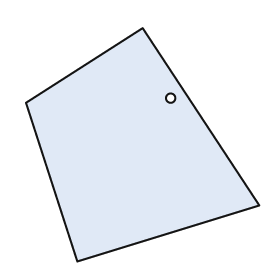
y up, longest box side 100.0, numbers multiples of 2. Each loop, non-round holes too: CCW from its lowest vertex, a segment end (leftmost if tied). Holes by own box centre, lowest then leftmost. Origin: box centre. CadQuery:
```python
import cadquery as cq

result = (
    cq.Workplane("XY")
    .moveTo(-28.0, -50.0)
    .lineTo(50.0, -26.0)
    .lineTo(0.0, 50.0)
    .lineTo(-50.0, 18.0)
    .close()
    .moveTo(12.0, 20.0)
    .circle(2.0)
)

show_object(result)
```